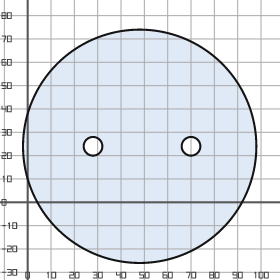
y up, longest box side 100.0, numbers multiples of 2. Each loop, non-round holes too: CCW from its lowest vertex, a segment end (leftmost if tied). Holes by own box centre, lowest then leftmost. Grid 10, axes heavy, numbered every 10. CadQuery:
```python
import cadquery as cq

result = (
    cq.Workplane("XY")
    .moveTo(48.0, 24.0)
    .circle(50.0)
    .moveTo(28.0, 24.0)
    .circle(4.0)
    .moveTo(70.0, 24.0)
    .circle(4.0)
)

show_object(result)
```